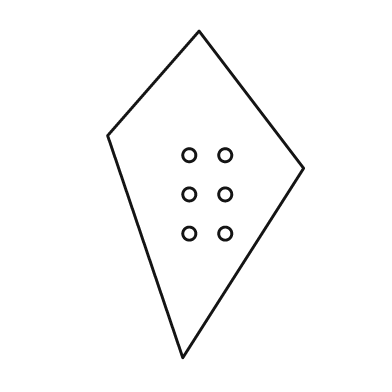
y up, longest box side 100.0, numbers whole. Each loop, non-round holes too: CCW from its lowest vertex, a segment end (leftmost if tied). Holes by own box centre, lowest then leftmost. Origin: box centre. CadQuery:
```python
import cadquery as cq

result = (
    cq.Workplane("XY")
    .moveTo(-7.0, -50.0)
    .lineTo(30.0, 8.0)
    .lineTo(-2.0, 50.0)
    .lineTo(-30.0, 18.0)
    .close()
    .moveTo(-5.0, -12.0)
    .circle(2.0)
    .moveTo(6.0, -12.0)
    .circle(2.0)
    .moveTo(-5.0, 0.0)
    .circle(2.0)
    .moveTo(6.0, 0.0)
    .circle(2.0)
    .moveTo(-5.0, 12.0)
    .circle(2.0)
    .moveTo(6.0, 12.0)
    .circle(2.0)
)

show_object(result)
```